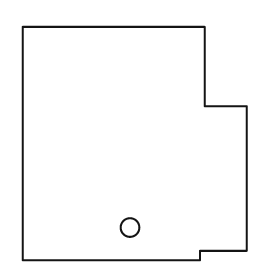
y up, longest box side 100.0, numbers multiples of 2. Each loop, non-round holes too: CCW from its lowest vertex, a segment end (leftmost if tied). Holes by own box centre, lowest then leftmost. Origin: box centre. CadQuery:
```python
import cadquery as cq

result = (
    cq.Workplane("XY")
    .moveTo(-48.0, -50.0)
    .lineTo(28.0, -50.0)
    .lineTo(28.0, -46.0)
    .lineTo(48.0, -46.0)
    .lineTo(48.0, 16.0)
    .lineTo(30.0, 16.0)
    .lineTo(30.0, 50.0)
    .lineTo(-48.0, 50.0)
    .close()
    .moveTo(-2.0, -36.0)
    .circle(4.0)
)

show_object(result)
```